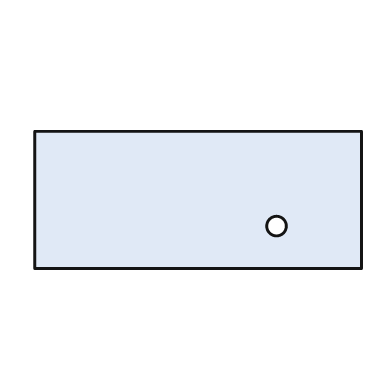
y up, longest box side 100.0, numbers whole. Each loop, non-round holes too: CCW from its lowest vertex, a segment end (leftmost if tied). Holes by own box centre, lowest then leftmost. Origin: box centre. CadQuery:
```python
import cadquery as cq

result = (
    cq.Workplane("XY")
    .moveTo(-50.0, -21.0)
    .lineTo(50.0, -21.0)
    .lineTo(50.0, 21.0)
    .lineTo(-50.0, 21.0)
    .close()
    .moveTo(24.0, -8.0)
    .circle(3.0)
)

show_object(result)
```